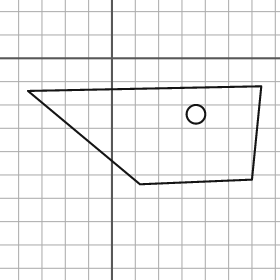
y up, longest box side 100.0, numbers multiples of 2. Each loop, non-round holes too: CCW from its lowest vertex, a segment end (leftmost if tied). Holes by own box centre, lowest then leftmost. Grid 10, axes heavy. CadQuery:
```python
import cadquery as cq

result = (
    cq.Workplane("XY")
    .moveTo(12.0, -54.0)
    .lineTo(60.0, -52.0)
    .lineTo(64.0, -12.0)
    .lineTo(-36.0, -14.0)
    .close()
    .moveTo(36.0, -24.0)
    .circle(4.0)
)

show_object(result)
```